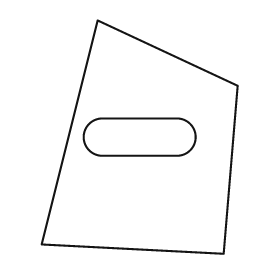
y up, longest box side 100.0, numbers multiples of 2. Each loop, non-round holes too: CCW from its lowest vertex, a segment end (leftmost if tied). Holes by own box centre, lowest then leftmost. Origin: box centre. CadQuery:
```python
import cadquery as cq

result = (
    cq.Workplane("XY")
    .moveTo(36.0, -50.0)
    .lineTo(42.0, 22.0)
    .lineTo(-18.0, 50.0)
    .lineTo(-42.0, -46.0)
    .close()
    .moveTo(-16.0, -8.0)
    .lineTo(16.0, -8.0)
    .threePointArc((24.0, 0.0), (16.0, 8.0))
    .lineTo(-16.0, 8.0)
    .threePointArc((-24.0, 0.0), (-16.0, -8.0))
    .close()
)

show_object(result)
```